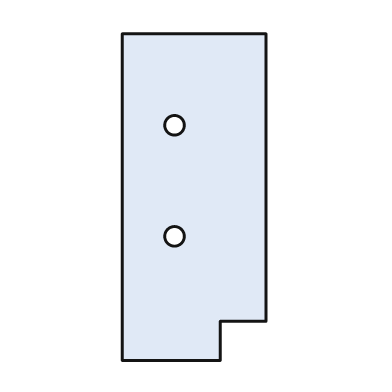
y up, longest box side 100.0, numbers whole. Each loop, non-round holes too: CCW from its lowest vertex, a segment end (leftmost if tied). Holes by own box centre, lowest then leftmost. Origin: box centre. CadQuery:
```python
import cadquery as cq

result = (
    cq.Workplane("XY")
    .moveTo(-22.0, -50.0)
    .lineTo(8.0, -50.0)
    .lineTo(8.0, -38.0)
    .lineTo(22.0, -38.0)
    .lineTo(22.0, 50.0)
    .lineTo(-22.0, 50.0)
    .close()
    .moveTo(-6.0, -12.0)
    .circle(3.0)
    .moveTo(-6.0, 22.0)
    .circle(3.0)
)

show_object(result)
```